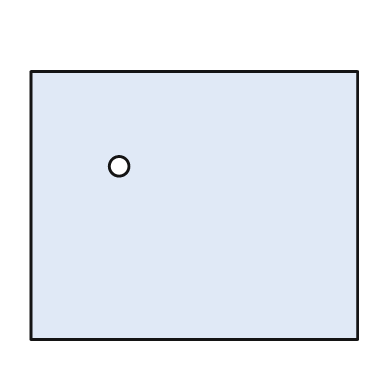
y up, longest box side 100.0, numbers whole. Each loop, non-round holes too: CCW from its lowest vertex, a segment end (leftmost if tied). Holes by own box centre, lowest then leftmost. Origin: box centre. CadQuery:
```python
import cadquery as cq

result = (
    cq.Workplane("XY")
    .moveTo(-50.0, -41.0)
    .lineTo(50.0, -41.0)
    .lineTo(50.0, 41.0)
    .lineTo(-50.0, 41.0)
    .close()
    .moveTo(-23.0, 12.0)
    .circle(3.0)
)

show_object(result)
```